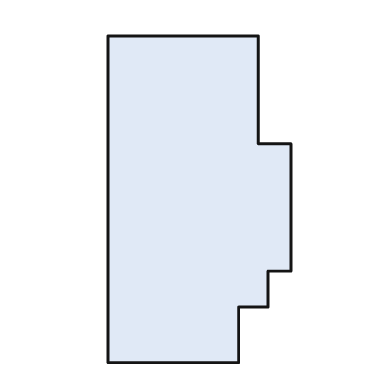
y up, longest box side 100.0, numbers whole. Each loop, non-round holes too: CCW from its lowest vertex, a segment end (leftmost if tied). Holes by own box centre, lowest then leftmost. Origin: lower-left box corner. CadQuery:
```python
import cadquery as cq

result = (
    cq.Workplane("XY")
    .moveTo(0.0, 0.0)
    .lineTo(40.0, 0.0)
    .lineTo(40.0, 17.0)
    .lineTo(49.0, 17.0)
    .lineTo(49.0, 28.0)
    .lineTo(56.0, 28.0)
    .lineTo(56.0, 67.0)
    .lineTo(46.0, 67.0)
    .lineTo(46.0, 100.0)
    .lineTo(0.0, 100.0)
    .close()
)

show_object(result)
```